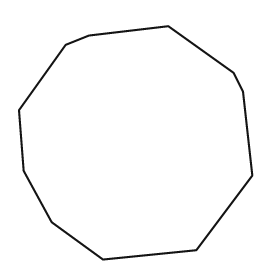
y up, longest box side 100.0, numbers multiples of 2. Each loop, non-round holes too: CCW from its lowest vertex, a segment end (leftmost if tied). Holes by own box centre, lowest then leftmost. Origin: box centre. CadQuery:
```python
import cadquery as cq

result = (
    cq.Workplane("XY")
    .moveTo(-14.0, -50.0)
    .lineTo(26.0, -46.0)
    .lineTo(50.0, -14.0)
    .lineTo(46.0, 22.0)
    .lineTo(42.0, 30.0)
    .lineTo(14.0, 50.0)
    .lineTo(-20.0, 46.0)
    .lineTo(-30.0, 42.0)
    .lineTo(-50.0, 14.0)
    .lineTo(-48.0, -12.0)
    .lineTo(-36.0, -34.0)
    .close()
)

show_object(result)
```